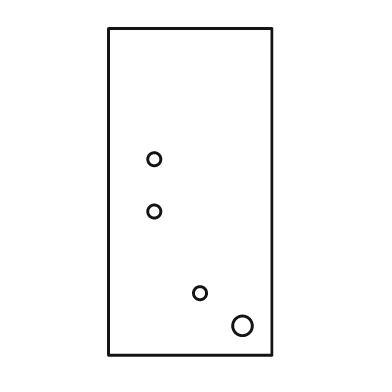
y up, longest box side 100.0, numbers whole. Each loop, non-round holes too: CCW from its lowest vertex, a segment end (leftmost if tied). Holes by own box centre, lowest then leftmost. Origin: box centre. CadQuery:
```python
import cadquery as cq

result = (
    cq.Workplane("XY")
    .moveTo(-25.0, -50.0)
    .lineTo(25.0, -50.0)
    .lineTo(25.0, 50.0)
    .lineTo(-25.0, 50.0)
    .close()
    .moveTo(16.0, -41.0)
    .circle(3.0)
    .moveTo(3.0, -31.0)
    .circle(2.0)
    .moveTo(-11.0, -6.0)
    .circle(2.0)
    .moveTo(-11.0, 10.0)
    .circle(2.0)
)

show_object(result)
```